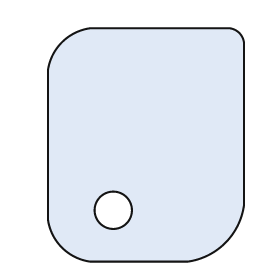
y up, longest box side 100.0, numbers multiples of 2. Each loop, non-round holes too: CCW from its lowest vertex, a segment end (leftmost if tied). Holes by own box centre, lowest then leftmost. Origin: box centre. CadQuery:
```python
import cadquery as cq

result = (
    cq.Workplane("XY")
    .moveTo(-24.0, -50.0)
    .lineTo(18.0, -50.0)
    .threePointArc((34.0, -42.0), (42.0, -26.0))
    .lineTo(42.0, 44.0)
    .threePointArc((40.0, 48.0), (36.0, 50.0))
    .lineTo(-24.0, 50.0)
    .threePointArc((-36.0, 44.0), (-42.0, 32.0))
    .lineTo(-42.0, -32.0)
    .threePointArc((-36.0, -44.0), (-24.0, -50.0))
    .close()
    .moveTo(-14.0, -28.0)
    .circle(8.0)
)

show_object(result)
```